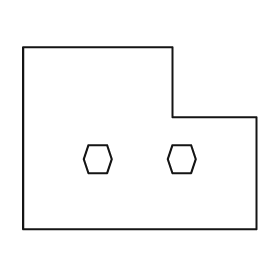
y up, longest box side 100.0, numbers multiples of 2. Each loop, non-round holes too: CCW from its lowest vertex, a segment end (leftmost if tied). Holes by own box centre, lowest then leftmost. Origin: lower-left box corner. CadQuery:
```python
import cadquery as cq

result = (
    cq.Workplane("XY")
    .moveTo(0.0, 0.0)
    .lineTo(100.0, 0.0)
    .lineTo(100.0, 48.0)
    .lineTo(64.0, 48.0)
    .lineTo(64.0, 78.0)
    .lineTo(0.0, 78.0)
    .close()
    .moveTo(28.0, 24.0)
    .lineTo(36.0, 24.0)
    .lineTo(38.0, 30.0)
    .lineTo(36.0, 36.0)
    .lineTo(28.0, 36.0)
    .lineTo(26.0, 30.0)
    .close()
    .moveTo(64.0, 24.0)
    .lineTo(72.0, 24.0)
    .lineTo(74.0, 30.0)
    .lineTo(72.0, 36.0)
    .lineTo(64.0, 36.0)
    .lineTo(62.0, 30.0)
    .close()
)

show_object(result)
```